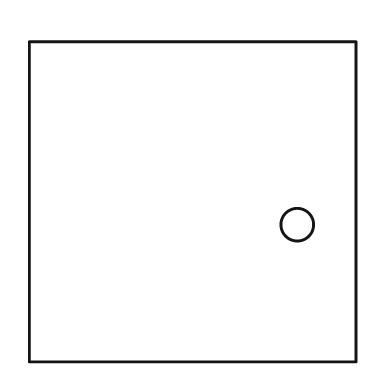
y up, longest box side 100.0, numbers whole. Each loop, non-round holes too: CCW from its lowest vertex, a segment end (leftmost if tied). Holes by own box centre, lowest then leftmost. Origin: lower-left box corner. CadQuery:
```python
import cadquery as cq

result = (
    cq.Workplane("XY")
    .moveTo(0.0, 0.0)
    .lineTo(100.0, 0.0)
    .lineTo(100.0, 98.0)
    .lineTo(0.0, 98.0)
    .close()
    .moveTo(82.0, 42.0)
    .circle(5.0)
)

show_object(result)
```